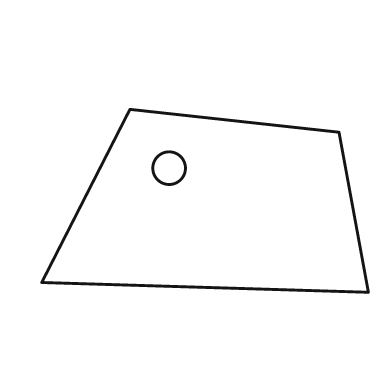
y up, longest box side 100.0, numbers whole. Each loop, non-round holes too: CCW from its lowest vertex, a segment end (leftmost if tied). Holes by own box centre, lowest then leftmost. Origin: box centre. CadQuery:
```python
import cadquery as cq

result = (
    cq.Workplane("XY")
    .moveTo(50.0, -28.0)
    .lineTo(41.0, 21.0)
    .lineTo(-23.0, 28.0)
    .lineTo(-50.0, -25.0)
    .close()
    .moveTo(-11.0, 10.0)
    .circle(5.0)
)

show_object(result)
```